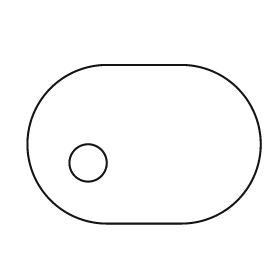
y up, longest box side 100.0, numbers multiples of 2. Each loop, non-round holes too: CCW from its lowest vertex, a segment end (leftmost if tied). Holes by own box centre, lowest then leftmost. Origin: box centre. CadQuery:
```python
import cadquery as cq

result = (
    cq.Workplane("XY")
    .moveTo(-16.0, -34.0)
    .lineTo(16.0, -34.0)
    .threePointArc((50.0, 0.0), (16.0, 34.0))
    .lineTo(-16.0, 34.0)
    .threePointArc((-50.0, 0.0), (-16.0, -34.0))
    .close()
    .moveTo(-24.0, -8.0)
    .circle(8.0)
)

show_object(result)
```